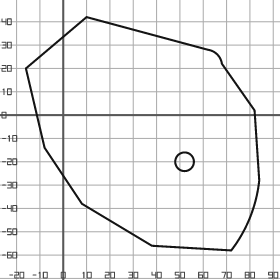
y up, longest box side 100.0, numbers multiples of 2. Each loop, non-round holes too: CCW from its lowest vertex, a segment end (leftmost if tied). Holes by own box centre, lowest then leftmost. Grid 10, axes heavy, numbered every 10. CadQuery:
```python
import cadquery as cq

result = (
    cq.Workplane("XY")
    .moveTo(72.0, -58.0)
    .threePointArc((80.0, -44.0), (84.0, -28.0))
    .lineTo(82.0, 2.0)
    .lineTo(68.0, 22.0)
    .threePointArc((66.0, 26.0), (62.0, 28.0))
    .lineTo(10.0, 42.0)
    .lineTo(-16.0, 20.0)
    .lineTo(-8.0, -14.0)
    .lineTo(8.0, -38.0)
    .lineTo(38.0, -56.0)
    .close()
    .moveTo(52.0, -20.0)
    .circle(4.0)
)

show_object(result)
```